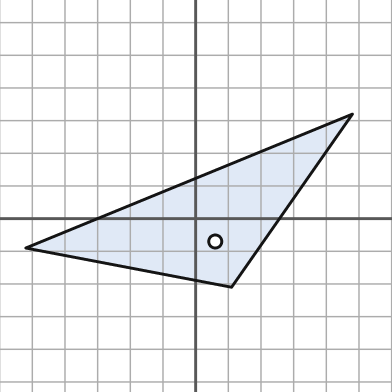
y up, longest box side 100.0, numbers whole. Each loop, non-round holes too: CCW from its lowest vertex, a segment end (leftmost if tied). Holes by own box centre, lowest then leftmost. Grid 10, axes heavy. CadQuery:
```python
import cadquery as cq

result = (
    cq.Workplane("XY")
    .moveTo(11.0, -21.0)
    .lineTo(48.0, 32.0)
    .lineTo(-52.0, -9.0)
    .close()
    .moveTo(6.0, -7.0)
    .circle(2.0)
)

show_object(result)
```